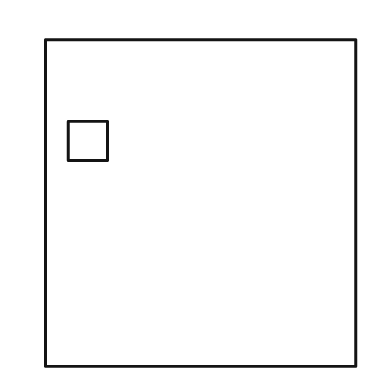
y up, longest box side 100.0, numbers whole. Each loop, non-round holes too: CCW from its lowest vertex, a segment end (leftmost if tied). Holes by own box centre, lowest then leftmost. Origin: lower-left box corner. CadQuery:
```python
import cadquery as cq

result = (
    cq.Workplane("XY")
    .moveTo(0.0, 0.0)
    .lineTo(95.0, 0.0)
    .lineTo(95.0, 100.0)
    .lineTo(0.0, 100.0)
    .close()
    .moveTo(7.0, 63.0)
    .lineTo(19.0, 63.0)
    .lineTo(19.0, 75.0)
    .lineTo(7.0, 75.0)
    .close()
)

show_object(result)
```